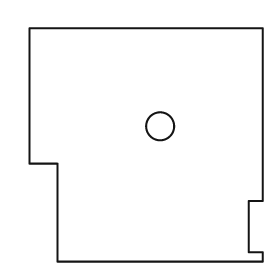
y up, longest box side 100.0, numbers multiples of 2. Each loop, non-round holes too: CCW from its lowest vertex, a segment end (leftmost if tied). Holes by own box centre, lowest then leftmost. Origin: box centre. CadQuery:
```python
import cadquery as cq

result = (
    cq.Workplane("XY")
    .moveTo(-38.0, -50.0)
    .lineTo(50.0, -50.0)
    .lineTo(50.0, -46.0)
    .lineTo(44.0, -46.0)
    .lineTo(44.0, -24.0)
    .lineTo(50.0, -24.0)
    .lineTo(50.0, 50.0)
    .lineTo(-50.0, 50.0)
    .lineTo(-50.0, -8.0)
    .lineTo(-38.0, -8.0)
    .close()
    .moveTo(6.0, 8.0)
    .circle(6.0)
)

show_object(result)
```